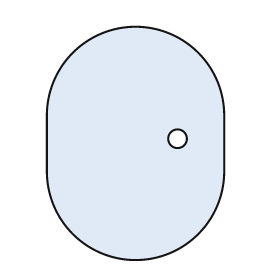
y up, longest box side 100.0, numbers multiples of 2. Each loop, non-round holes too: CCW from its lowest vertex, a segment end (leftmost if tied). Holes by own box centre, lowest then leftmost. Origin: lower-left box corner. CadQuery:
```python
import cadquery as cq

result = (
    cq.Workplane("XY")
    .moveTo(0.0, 38.0)
    .threePointArc((38.0, 0.0), (76.0, 38.0))
    .lineTo(76.0, 62.0)
    .threePointArc((38.0, 100.0), (0.0, 62.0))
    .close()
    .moveTo(56.0, 52.0)
    .circle(4.0)
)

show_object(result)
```